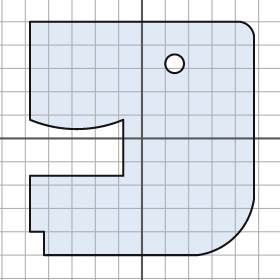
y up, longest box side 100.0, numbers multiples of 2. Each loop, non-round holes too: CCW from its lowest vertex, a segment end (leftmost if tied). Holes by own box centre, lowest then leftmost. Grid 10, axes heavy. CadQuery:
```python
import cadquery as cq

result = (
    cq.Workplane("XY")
    .moveTo(-42.0, -50.0)
    .lineTo(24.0, -50.0)
    .threePointArc((40.0, -42.0), (48.0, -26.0))
    .lineTo(48.0, 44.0)
    .threePointArc((46.0, 48.0), (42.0, 50.0))
    .lineTo(-48.0, 50.0)
    .lineTo(-48.0, 8.0)
    .threePointArc((-28.0, 4.0), (-8.0, 8.0))
    .lineTo(-8.0, -16.0)
    .lineTo(-48.0, -16.0)
    .lineTo(-48.0, -40.0)
    .lineTo(-42.0, -40.0)
    .close()
    .moveTo(14.0, 32.0)
    .circle(4.0)
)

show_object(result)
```